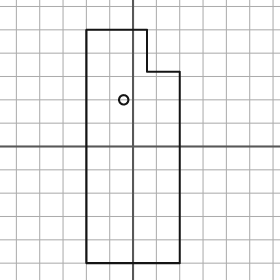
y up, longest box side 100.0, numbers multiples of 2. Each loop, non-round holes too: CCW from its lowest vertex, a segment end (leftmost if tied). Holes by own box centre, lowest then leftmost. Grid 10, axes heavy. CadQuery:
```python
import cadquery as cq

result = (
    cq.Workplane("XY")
    .moveTo(-20.0, -50.0)
    .lineTo(20.0, -50.0)
    .lineTo(20.0, 32.0)
    .lineTo(6.0, 32.0)
    .lineTo(6.0, 50.0)
    .lineTo(-20.0, 50.0)
    .close()
    .moveTo(-4.0, 20.0)
    .circle(2.0)
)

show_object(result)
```